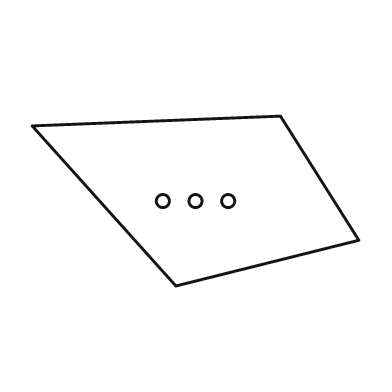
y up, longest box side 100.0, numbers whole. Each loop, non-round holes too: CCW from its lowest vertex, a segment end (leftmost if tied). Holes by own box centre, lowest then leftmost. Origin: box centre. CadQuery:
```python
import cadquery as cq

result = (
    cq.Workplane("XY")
    .moveTo(-6.0, -26.0)
    .lineTo(50.0, -12.0)
    .lineTo(26.0, 26.0)
    .lineTo(-50.0, 23.0)
    .close()
    .moveTo(-10.0, 0.0)
    .circle(2.0)
    .moveTo(0.0, 0.0)
    .circle(2.0)
    .moveTo(10.0, 0.0)
    .circle(2.0)
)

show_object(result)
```